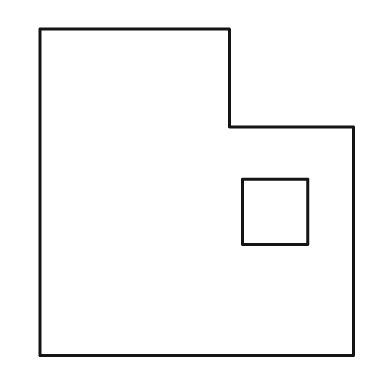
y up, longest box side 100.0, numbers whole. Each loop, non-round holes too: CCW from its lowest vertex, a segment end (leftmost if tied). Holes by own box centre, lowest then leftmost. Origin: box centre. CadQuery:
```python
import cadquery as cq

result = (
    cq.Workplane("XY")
    .moveTo(-48.0, -50.0)
    .lineTo(48.0, -50.0)
    .lineTo(48.0, 20.0)
    .lineTo(10.0, 20.0)
    .lineTo(10.0, 50.0)
    .lineTo(-48.0, 50.0)
    .close()
    .moveTo(14.0, -16.0)
    .lineTo(34.0, -16.0)
    .lineTo(34.0, 4.0)
    .lineTo(14.0, 4.0)
    .close()
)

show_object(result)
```